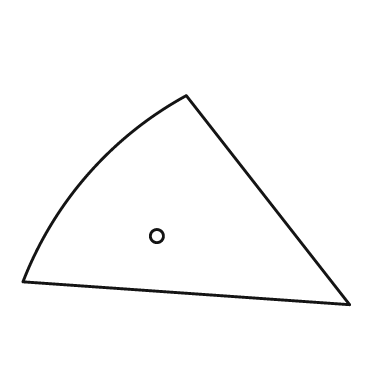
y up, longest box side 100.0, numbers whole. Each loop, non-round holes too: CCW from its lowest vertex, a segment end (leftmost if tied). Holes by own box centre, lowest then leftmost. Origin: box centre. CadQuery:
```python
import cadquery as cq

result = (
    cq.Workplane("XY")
    .moveTo(50.0, -32.0)
    .lineTo(0.0, 32.0)
    .threePointArc((-30.0, 8.0), (-50.0, -25.0))
    .close()
    .moveTo(-9.0, -11.0)
    .circle(2.0)
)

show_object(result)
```